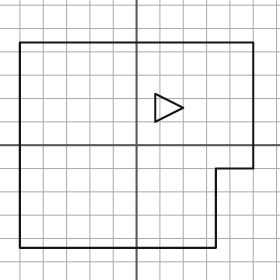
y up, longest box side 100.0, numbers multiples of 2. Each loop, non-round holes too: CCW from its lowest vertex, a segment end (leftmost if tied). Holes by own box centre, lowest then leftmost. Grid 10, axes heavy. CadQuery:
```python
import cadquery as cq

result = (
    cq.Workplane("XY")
    .moveTo(-50.0, -44.0)
    .lineTo(34.0, -44.0)
    .lineTo(34.0, -10.0)
    .lineTo(50.0, -10.0)
    .lineTo(50.0, 44.0)
    .lineTo(-50.0, 44.0)
    .close()
    .moveTo(8.0, 10.0)
    .lineTo(20.0, 16.0)
    .lineTo(8.0, 22.0)
    .close()
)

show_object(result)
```